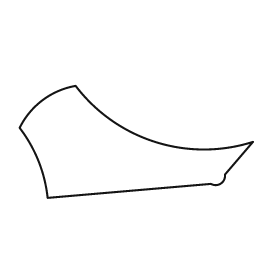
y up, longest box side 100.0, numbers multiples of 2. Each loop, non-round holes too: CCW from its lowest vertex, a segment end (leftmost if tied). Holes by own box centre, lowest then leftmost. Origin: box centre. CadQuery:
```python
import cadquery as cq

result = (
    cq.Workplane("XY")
    .moveTo(-38.0, -24.0)
    .lineTo(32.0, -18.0)
    .threePointArc((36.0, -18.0), (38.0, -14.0))
    .lineTo(50.0, 0.0)
    .threePointArc((8.0, 0.0), (-26.0, 24.0))
    .threePointArc((-40.0, 18.0), (-50.0, 6.0))
    .threePointArc((-42.0, -8.0), (-38.0, -24.0))
    .close()
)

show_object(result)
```